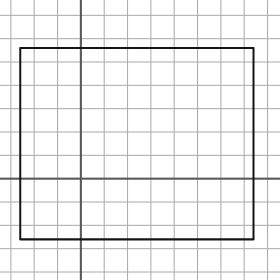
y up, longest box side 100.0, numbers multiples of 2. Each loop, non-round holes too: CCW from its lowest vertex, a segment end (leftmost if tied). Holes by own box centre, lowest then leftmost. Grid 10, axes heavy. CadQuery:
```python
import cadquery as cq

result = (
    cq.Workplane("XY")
    .moveTo(-26.0, -26.0)
    .lineTo(74.0, -26.0)
    .lineTo(74.0, 56.0)
    .lineTo(-26.0, 56.0)
    .close()
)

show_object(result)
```